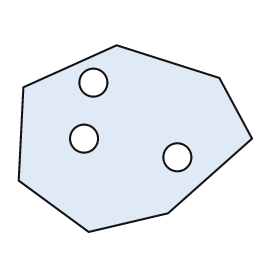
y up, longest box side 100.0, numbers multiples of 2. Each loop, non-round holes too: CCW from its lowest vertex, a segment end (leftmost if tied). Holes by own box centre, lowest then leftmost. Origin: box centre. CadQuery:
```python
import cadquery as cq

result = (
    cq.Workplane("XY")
    .moveTo(-20.0, -40.0)
    .lineTo(14.0, -32.0)
    .lineTo(50.0, 0.0)
    .lineTo(36.0, 26.0)
    .lineTo(-8.0, 40.0)
    .lineTo(-48.0, 22.0)
    .lineTo(-50.0, -18.0)
    .close()
    .moveTo(18.0, -8.0)
    .circle(6.0)
    .moveTo(-22.0, 0.0)
    .circle(6.0)
    .moveTo(-18.0, 24.0)
    .circle(6.0)
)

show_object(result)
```